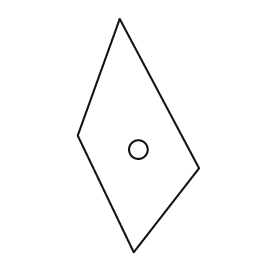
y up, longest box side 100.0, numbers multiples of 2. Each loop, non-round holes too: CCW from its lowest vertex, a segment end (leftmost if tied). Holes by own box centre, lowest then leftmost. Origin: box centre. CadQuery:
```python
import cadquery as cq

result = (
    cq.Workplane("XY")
    .moveTo(-2.0, -50.0)
    .lineTo(26.0, -14.0)
    .lineTo(-8.0, 50.0)
    .lineTo(-26.0, 0.0)
    .close()
    .moveTo(0.0, -6.0)
    .circle(4.0)
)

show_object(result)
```